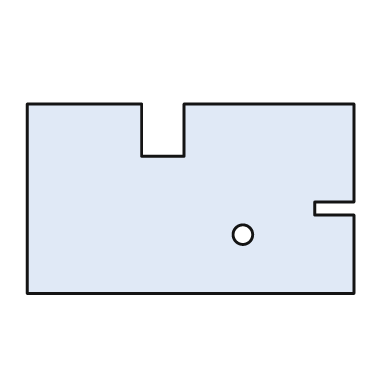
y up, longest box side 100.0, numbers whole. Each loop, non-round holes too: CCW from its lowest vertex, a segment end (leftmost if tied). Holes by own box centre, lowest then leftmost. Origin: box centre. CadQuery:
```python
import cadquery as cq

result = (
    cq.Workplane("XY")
    .moveTo(-50.0, -29.0)
    .lineTo(50.0, -29.0)
    .lineTo(50.0, -5.0)
    .lineTo(38.0, -5.0)
    .lineTo(38.0, -1.0)
    .lineTo(50.0, -1.0)
    .lineTo(50.0, 29.0)
    .lineTo(-2.0, 29.0)
    .lineTo(-2.0, 13.0)
    .lineTo(-15.0, 13.0)
    .lineTo(-15.0, 29.0)
    .lineTo(-50.0, 29.0)
    .close()
    .moveTo(16.0, -11.0)
    .circle(3.0)
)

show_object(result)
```